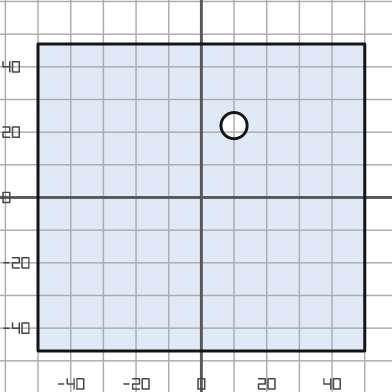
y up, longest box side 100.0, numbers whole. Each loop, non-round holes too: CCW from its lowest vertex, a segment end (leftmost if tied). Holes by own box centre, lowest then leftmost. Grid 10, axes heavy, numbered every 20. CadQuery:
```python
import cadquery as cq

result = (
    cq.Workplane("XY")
    .moveTo(-50.0, -47.0)
    .lineTo(50.0, -47.0)
    .lineTo(50.0, 47.0)
    .lineTo(-50.0, 47.0)
    .close()
    .moveTo(10.0, 22.0)
    .circle(4.0)
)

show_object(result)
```